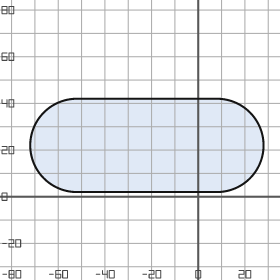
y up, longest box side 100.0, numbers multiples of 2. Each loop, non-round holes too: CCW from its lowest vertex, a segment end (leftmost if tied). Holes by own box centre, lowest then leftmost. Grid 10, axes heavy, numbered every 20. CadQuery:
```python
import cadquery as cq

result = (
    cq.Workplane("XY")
    .moveTo(-52.0, 2.0)
    .lineTo(8.0, 2.0)
    .threePointArc((28.0, 22.0), (8.0, 42.0))
    .lineTo(-52.0, 42.0)
    .threePointArc((-72.0, 22.0), (-52.0, 2.0))
    .close()
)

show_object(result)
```